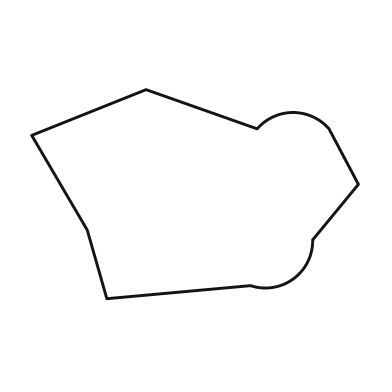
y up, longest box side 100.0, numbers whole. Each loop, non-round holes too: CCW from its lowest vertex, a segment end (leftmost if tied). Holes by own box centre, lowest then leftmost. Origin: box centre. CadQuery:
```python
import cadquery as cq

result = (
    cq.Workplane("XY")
    .moveTo(-27.0, -32.0)
    .lineTo(17.0, -28.0)
    .threePointArc((30.0, -26.0), (36.0, -14.0))
    .lineTo(50.0, 3.0)
    .lineTo(41.0, 20.0)
    .threePointArc((30.0, 25.0), (19.0, 20.0))
    .lineTo(-15.0, 32.0)
    .lineTo(-50.0, 18.0)
    .lineTo(-33.0, -11.0)
    .close()
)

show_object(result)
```